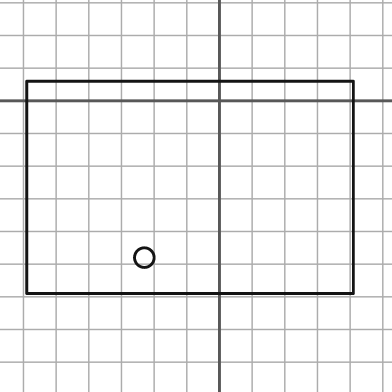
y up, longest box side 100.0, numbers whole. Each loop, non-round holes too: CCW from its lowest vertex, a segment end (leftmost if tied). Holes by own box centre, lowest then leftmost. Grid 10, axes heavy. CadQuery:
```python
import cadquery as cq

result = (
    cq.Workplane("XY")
    .moveTo(-59.0, -59.0)
    .lineTo(41.0, -59.0)
    .lineTo(41.0, 6.0)
    .lineTo(-59.0, 6.0)
    .close()
    .moveTo(-23.0, -48.0)
    .circle(3.0)
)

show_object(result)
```